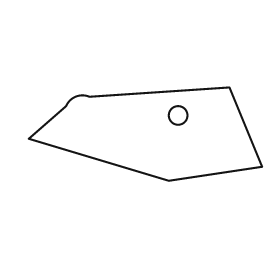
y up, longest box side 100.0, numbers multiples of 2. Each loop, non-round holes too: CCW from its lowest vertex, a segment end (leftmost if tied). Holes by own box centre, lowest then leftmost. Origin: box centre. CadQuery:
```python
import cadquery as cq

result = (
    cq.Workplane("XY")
    .moveTo(10.0, -20.0)
    .lineTo(50.0, -14.0)
    .lineTo(36.0, 20.0)
    .lineTo(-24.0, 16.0)
    .threePointArc((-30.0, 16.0), (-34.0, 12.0))
    .lineTo(-50.0, -2.0)
    .close()
    .moveTo(14.0, 8.0)
    .circle(4.0)
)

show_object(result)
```